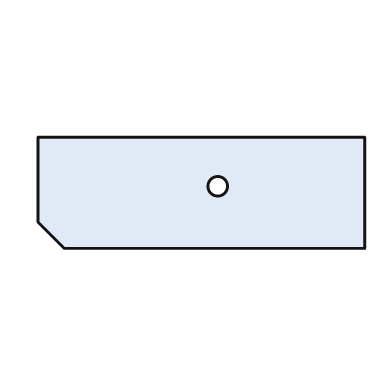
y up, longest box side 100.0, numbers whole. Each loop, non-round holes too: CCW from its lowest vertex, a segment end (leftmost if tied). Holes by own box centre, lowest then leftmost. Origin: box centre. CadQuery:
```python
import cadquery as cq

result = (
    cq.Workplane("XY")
    .moveTo(-42.0, -17.0)
    .lineTo(50.0, -17.0)
    .lineTo(50.0, 17.0)
    .lineTo(-50.0, 17.0)
    .lineTo(-50.0, -9.0)
    .close()
    .moveTo(5.0, 2.0)
    .circle(3.0)
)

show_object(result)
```